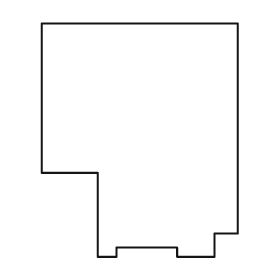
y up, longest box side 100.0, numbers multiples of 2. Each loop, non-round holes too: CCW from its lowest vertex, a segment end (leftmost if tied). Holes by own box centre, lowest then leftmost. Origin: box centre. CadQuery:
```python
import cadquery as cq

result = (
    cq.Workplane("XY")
    .moveTo(-18.0, -50.0)
    .lineTo(-10.0, -50.0)
    .lineTo(-10.0, -46.0)
    .lineTo(16.0, -46.0)
    .lineTo(16.0, -50.0)
    .lineTo(32.0, -50.0)
    .lineTo(32.0, -40.0)
    .lineTo(42.0, -40.0)
    .lineTo(42.0, 50.0)
    .lineTo(-42.0, 50.0)
    .lineTo(-42.0, -14.0)
    .lineTo(-18.0, -14.0)
    .close()
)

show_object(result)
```